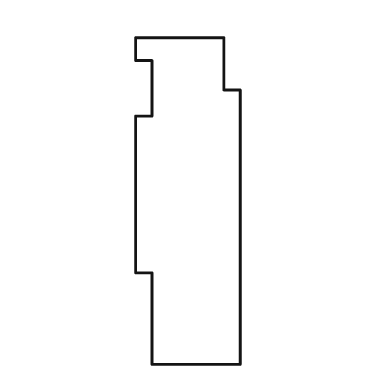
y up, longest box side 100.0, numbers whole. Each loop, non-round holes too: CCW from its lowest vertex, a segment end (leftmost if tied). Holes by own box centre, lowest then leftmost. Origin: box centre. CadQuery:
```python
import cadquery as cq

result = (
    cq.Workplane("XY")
    .moveTo(-11.0, -50.0)
    .lineTo(16.0, -50.0)
    .lineTo(16.0, 34.0)
    .lineTo(11.0, 34.0)
    .lineTo(11.0, 50.0)
    .lineTo(-16.0, 50.0)
    .lineTo(-16.0, 43.0)
    .lineTo(-11.0, 43.0)
    .lineTo(-11.0, 26.0)
    .lineTo(-16.0, 26.0)
    .lineTo(-16.0, -22.0)
    .lineTo(-11.0, -22.0)
    .close()
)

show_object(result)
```